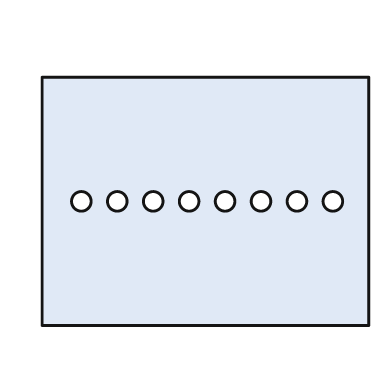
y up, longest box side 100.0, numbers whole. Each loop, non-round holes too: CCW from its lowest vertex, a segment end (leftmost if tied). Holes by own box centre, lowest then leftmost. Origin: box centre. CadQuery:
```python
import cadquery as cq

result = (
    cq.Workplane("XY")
    .moveTo(-50.0, -38.0)
    .lineTo(50.0, -38.0)
    .lineTo(50.0, 38.0)
    .lineTo(-50.0, 38.0)
    .close()
    .moveTo(-38.0, 0.0)
    .circle(3.0)
    .moveTo(-27.0, 0.0)
    .circle(3.0)
    .moveTo(-16.0, 0.0)
    .circle(3.0)
    .moveTo(-5.0, 0.0)
    .circle(3.0)
    .moveTo(6.0, 0.0)
    .circle(3.0)
    .moveTo(17.0, 0.0)
    .circle(3.0)
    .moveTo(28.0, 0.0)
    .circle(3.0)
    .moveTo(39.0, 0.0)
    .circle(3.0)
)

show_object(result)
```